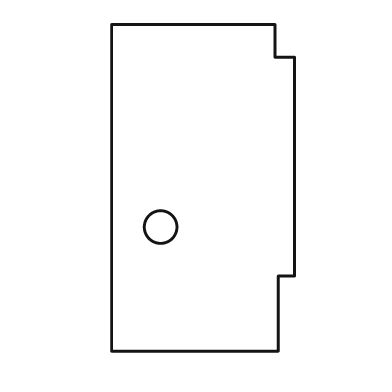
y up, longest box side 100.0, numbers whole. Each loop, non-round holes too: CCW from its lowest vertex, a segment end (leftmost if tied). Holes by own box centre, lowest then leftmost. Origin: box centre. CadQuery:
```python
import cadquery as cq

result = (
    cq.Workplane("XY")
    .moveTo(-28.0, -50.0)
    .lineTo(23.0, -50.0)
    .lineTo(23.0, -27.0)
    .lineTo(28.0, -27.0)
    .lineTo(28.0, 40.0)
    .lineTo(22.0, 40.0)
    .lineTo(22.0, 50.0)
    .lineTo(-28.0, 50.0)
    .close()
    .moveTo(-13.0, -12.0)
    .circle(5.0)
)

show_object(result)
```